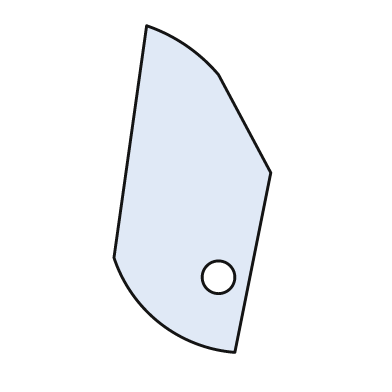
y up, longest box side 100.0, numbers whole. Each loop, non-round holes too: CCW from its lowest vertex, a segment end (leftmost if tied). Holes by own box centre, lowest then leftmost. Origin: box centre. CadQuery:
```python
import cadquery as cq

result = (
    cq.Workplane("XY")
    .moveTo(13.0, -50.0)
    .lineTo(24.0, 5.0)
    .lineTo(8.0, 35.0)
    .threePointArc((-2.0, 44.0), (-14.0, 50.0))
    .lineTo(-24.0, -21.0)
    .threePointArc((-10.0, -41.0), (13.0, -50.0))
    .close()
    .moveTo(8.0, -27.0)
    .circle(5.0)
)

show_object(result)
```